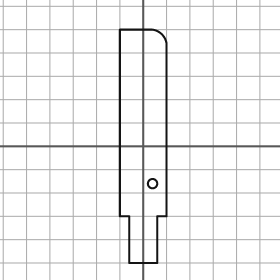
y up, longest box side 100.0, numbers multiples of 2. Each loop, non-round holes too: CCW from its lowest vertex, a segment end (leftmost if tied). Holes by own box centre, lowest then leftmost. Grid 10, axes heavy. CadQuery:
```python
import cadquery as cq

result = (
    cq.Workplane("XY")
    .moveTo(-6.0, -50.0)
    .lineTo(6.0, -50.0)
    .lineTo(6.0, -30.0)
    .lineTo(10.0, -30.0)
    .lineTo(10.0, 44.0)
    .threePointArc((8.0, 48.0), (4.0, 50.0))
    .lineTo(-10.0, 50.0)
    .lineTo(-10.0, -30.0)
    .lineTo(-6.0, -30.0)
    .close()
    .moveTo(4.0, -16.0)
    .circle(2.0)
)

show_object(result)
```